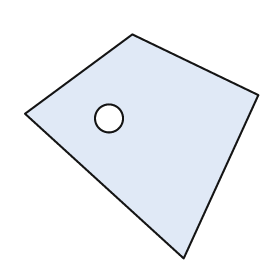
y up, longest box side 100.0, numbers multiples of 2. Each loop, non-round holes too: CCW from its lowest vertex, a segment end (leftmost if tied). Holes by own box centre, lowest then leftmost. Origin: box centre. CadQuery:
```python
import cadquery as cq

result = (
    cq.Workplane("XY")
    .moveTo(18.0, -48.0)
    .lineTo(50.0, 22.0)
    .lineTo(-4.0, 48.0)
    .lineTo(-50.0, 14.0)
    .close()
    .moveTo(-14.0, 12.0)
    .circle(6.0)
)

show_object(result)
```